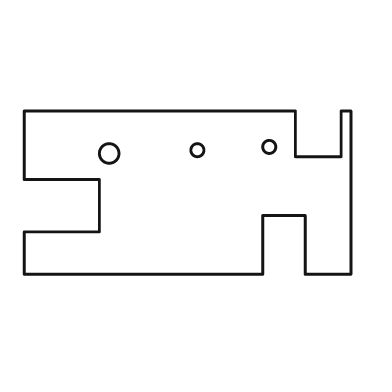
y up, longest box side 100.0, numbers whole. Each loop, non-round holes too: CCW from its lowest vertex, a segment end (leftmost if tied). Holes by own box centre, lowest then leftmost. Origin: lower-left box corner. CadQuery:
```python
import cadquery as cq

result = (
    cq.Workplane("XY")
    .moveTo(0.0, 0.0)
    .lineTo(73.0, 0.0)
    .lineTo(73.0, 18.0)
    .lineTo(86.0, 18.0)
    .lineTo(86.0, 0.0)
    .lineTo(100.0, 0.0)
    .lineTo(100.0, 50.0)
    .lineTo(97.0, 50.0)
    .lineTo(97.0, 36.0)
    .lineTo(83.0, 36.0)
    .lineTo(83.0, 50.0)
    .lineTo(0.0, 50.0)
    .lineTo(0.0, 29.0)
    .lineTo(23.0, 29.0)
    .lineTo(23.0, 13.0)
    .lineTo(0.0, 13.0)
    .close()
    .moveTo(26.0, 37.0)
    .circle(3.0)
    .moveTo(53.0, 38.0)
    .circle(2.0)
    .moveTo(75.0, 39.0)
    .circle(2.0)
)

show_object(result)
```